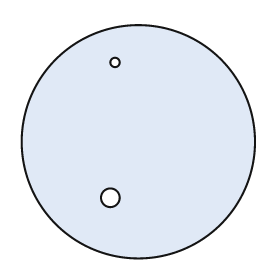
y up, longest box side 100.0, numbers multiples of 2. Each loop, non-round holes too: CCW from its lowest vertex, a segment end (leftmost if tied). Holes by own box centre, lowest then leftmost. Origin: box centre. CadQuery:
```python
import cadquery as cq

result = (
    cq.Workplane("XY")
    .moveTo(0.0, 0.0)
    .circle(50.0)
    .moveTo(-12.0, -24.0)
    .circle(4.0)
    .moveTo(-10.0, 34.0)
    .circle(2.0)
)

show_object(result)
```